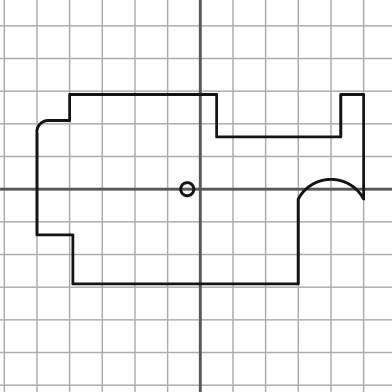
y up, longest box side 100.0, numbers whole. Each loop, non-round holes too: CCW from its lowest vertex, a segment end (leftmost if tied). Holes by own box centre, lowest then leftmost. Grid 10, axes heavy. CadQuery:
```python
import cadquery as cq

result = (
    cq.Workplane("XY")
    .moveTo(-39.0, -29.0)
    .lineTo(30.0, -29.0)
    .lineTo(30.0, -3.0)
    .threePointArc((40.0, 3.0), (50.0, -3.0))
    .lineTo(50.0, 29.0)
    .lineTo(43.0, 29.0)
    .lineTo(43.0, 16.0)
    .lineTo(5.0, 16.0)
    .lineTo(5.0, 29.0)
    .lineTo(-40.0, 29.0)
    .lineTo(-40.0, 21.0)
    .lineTo(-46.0, 21.0)
    .threePointArc((-49.0, 20.0), (-50.0, 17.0))
    .lineTo(-50.0, -14.0)
    .lineTo(-39.0, -14.0)
    .close()
    .moveTo(-4.0, 0.0)
    .circle(2.0)
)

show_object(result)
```